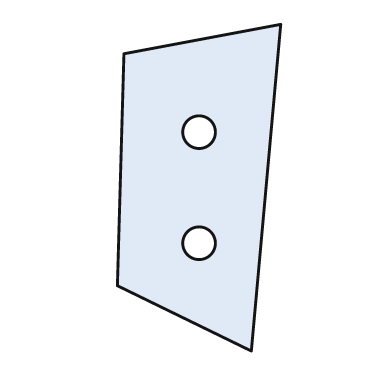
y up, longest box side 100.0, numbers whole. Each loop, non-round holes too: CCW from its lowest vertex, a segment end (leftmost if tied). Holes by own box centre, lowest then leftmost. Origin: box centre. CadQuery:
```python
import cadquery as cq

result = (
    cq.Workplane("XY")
    .moveTo(16.0, -50.0)
    .lineTo(25.0, 50.0)
    .lineTo(-23.0, 41.0)
    .lineTo(-25.0, -30.0)
    .close()
    .moveTo(0.0, -17.0)
    .circle(5.0)
    .moveTo(0.0, 17.0)
    .circle(5.0)
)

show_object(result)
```